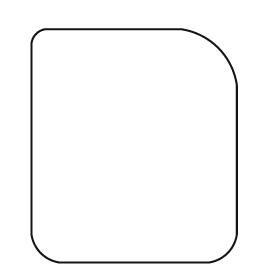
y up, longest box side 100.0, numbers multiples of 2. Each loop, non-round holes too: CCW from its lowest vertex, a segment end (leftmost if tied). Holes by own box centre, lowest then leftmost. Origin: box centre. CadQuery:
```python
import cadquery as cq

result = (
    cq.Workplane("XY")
    .moveTo(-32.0, -50.0)
    .lineTo(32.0, -50.0)
    .threePointArc((40.0, -46.0), (44.0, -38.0))
    .lineTo(44.0, 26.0)
    .threePointArc((36.0, 42.0), (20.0, 50.0))
    .lineTo(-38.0, 50.0)
    .threePointArc((-42.0, 48.0), (-44.0, 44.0))
    .lineTo(-44.0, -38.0)
    .threePointArc((-40.0, -46.0), (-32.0, -50.0))
    .close()
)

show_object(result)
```